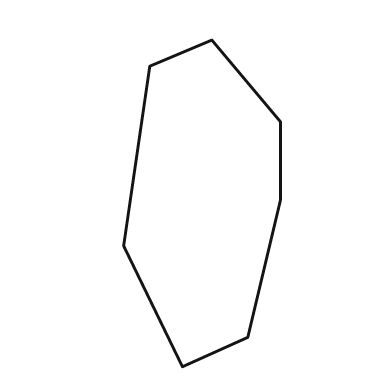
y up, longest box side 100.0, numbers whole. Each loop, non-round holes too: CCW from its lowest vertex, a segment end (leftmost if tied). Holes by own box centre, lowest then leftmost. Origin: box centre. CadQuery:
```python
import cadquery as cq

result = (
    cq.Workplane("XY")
    .moveTo(-6.0, -50.0)
    .lineTo(14.0, -41.0)
    .lineTo(24.0, 1.0)
    .lineTo(24.0, 25.0)
    .lineTo(3.0, 50.0)
    .lineTo(-16.0, 42.0)
    .lineTo(-24.0, -13.0)
    .close()
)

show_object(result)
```